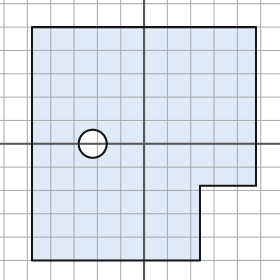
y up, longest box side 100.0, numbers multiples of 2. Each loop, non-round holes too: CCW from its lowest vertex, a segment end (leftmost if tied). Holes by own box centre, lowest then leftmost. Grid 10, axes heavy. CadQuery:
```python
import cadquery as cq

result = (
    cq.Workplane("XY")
    .moveTo(-48.0, -50.0)
    .lineTo(24.0, -50.0)
    .lineTo(24.0, -18.0)
    .lineTo(48.0, -18.0)
    .lineTo(48.0, 50.0)
    .lineTo(-48.0, 50.0)
    .close()
    .moveTo(-22.0, 0.0)
    .circle(6.0)
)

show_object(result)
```